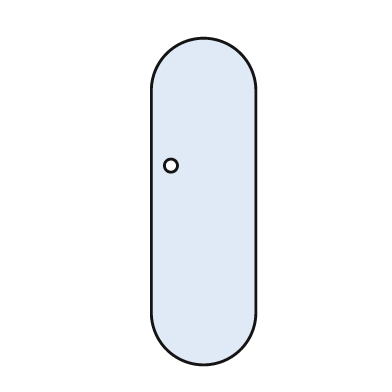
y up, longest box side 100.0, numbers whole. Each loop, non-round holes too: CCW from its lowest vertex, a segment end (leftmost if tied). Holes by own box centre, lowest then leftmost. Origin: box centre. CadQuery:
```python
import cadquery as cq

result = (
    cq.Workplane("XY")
    .moveTo(-16.0, -34.0)
    .threePointArc((0.0, -50.0), (16.0, -34.0))
    .lineTo(16.0, 34.0)
    .threePointArc((0.0, 50.0), (-16.0, 34.0))
    .close()
    .moveTo(-10.0, 11.0)
    .circle(2.0)
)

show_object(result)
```